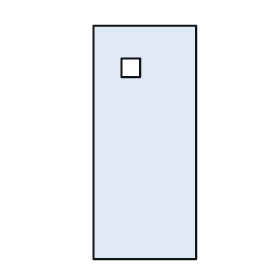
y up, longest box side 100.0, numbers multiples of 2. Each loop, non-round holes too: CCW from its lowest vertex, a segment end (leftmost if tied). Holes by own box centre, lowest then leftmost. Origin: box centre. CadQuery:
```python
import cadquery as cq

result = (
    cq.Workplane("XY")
    .moveTo(-22.0, -50.0)
    .lineTo(22.0, -50.0)
    .lineTo(22.0, 50.0)
    .lineTo(-22.0, 50.0)
    .close()
    .moveTo(-10.0, 28.0)
    .lineTo(-2.0, 28.0)
    .lineTo(-2.0, 36.0)
    .lineTo(-10.0, 36.0)
    .close()
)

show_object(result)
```